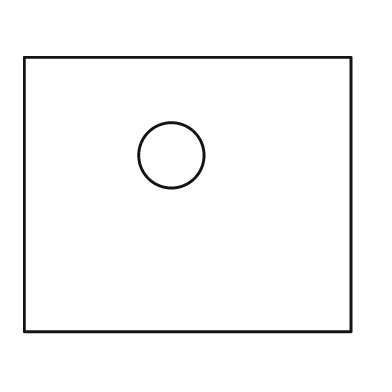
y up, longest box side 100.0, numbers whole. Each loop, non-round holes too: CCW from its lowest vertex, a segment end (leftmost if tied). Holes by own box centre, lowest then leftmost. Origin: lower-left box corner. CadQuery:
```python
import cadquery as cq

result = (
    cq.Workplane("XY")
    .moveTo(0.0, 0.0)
    .lineTo(100.0, 0.0)
    .lineTo(100.0, 84.0)
    .lineTo(0.0, 84.0)
    .close()
    .moveTo(45.0, 54.0)
    .circle(10.0)
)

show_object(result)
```